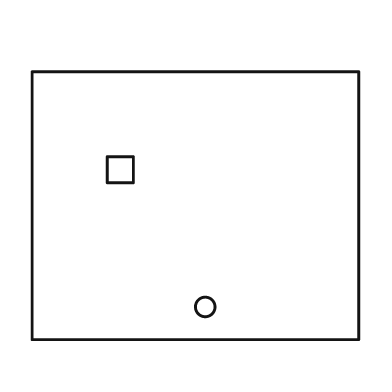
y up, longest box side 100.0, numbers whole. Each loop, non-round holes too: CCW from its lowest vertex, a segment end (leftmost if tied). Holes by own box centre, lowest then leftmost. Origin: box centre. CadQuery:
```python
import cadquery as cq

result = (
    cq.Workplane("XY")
    .moveTo(-50.0, -41.0)
    .lineTo(50.0, -41.0)
    .lineTo(50.0, 41.0)
    .lineTo(-50.0, 41.0)
    .close()
    .moveTo(3.0, -31.0)
    .circle(3.0)
    .moveTo(-27.0, 7.0)
    .lineTo(-19.0, 7.0)
    .lineTo(-19.0, 15.0)
    .lineTo(-27.0, 15.0)
    .close()
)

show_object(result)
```